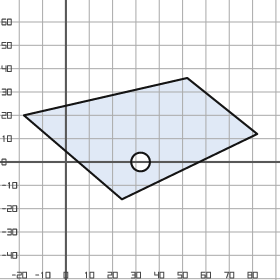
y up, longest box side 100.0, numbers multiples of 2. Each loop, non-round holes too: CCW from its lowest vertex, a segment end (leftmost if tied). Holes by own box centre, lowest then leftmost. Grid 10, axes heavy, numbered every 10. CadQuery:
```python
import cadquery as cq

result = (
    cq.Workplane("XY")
    .moveTo(24.0, -16.0)
    .lineTo(82.0, 12.0)
    .lineTo(52.0, 36.0)
    .lineTo(-18.0, 20.0)
    .close()
    .moveTo(32.0, 0.0)
    .circle(4.0)
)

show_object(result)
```